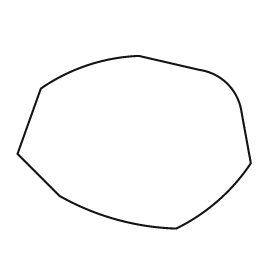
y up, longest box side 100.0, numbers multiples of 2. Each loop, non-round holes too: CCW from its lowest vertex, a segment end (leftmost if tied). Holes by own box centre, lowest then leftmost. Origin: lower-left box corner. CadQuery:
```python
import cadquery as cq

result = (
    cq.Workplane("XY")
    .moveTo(68.0, 0.0)
    .threePointArc((86.0, 12.0), (100.0, 28.0))
    .lineTo(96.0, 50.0)
    .threePointArc((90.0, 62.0), (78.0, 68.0))
    .lineTo(52.0, 74.0)
    .threePointArc((30.0, 70.0), (10.0, 60.0))
    .lineTo(0.0, 32.0)
    .lineTo(18.0, 14.0)
    .threePointArc((42.0, 4.0), (68.0, 0.0))
    .close()
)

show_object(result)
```